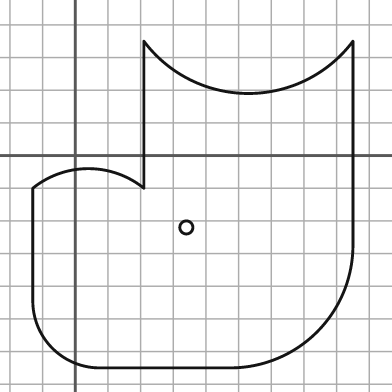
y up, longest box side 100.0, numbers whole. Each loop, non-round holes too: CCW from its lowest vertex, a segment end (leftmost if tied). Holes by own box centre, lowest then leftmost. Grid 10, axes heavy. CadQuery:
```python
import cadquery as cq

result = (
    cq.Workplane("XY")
    .moveTo(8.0, -65.0)
    .lineTo(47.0, -65.0)
    .threePointArc((74.0, -54.0), (85.0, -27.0))
    .lineTo(85.0, 35.0)
    .threePointArc((53.0, 19.0), (21.0, 35.0))
    .lineTo(21.0, -10.0)
    .threePointArc((4.0, -4.0), (-13.0, -10.0))
    .lineTo(-13.0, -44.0)
    .threePointArc((-7.0, -59.0), (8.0, -65.0))
    .close()
    .moveTo(34.0, -22.0)
    .circle(2.0)
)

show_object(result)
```